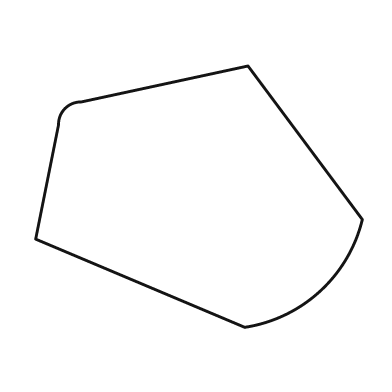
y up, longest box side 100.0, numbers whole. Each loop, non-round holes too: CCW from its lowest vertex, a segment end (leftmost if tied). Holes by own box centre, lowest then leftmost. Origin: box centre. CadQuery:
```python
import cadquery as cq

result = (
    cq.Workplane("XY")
    .moveTo(14.0, -40.0)
    .threePointArc((37.0, -29.0), (50.0, -7.0))
    .lineTo(15.0, 40.0)
    .lineTo(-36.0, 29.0)
    .threePointArc((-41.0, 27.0), (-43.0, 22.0))
    .lineTo(-50.0, -13.0)
    .close()
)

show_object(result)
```